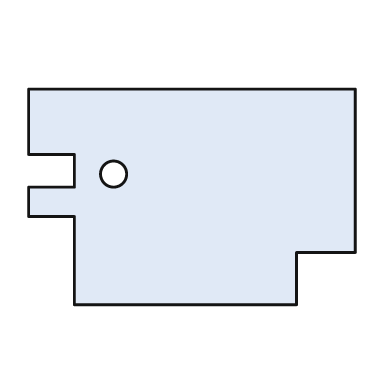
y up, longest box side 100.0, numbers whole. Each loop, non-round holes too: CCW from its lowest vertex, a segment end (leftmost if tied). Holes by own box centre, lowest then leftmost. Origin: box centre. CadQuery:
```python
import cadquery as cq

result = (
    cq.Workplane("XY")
    .moveTo(-36.0, -33.0)
    .lineTo(32.0, -33.0)
    .lineTo(32.0, -17.0)
    .lineTo(50.0, -17.0)
    .lineTo(50.0, 33.0)
    .lineTo(-50.0, 33.0)
    .lineTo(-50.0, 13.0)
    .lineTo(-36.0, 13.0)
    .lineTo(-36.0, 3.0)
    .lineTo(-50.0, 3.0)
    .lineTo(-50.0, -6.0)
    .lineTo(-36.0, -6.0)
    .close()
    .moveTo(-24.0, 7.0)
    .circle(4.0)
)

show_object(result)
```